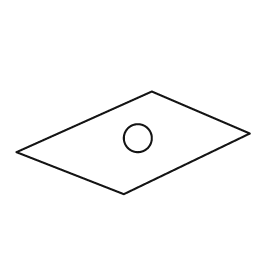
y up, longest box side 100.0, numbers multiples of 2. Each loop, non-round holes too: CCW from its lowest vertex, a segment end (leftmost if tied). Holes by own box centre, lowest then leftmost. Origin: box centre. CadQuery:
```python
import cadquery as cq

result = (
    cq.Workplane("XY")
    .moveTo(-4.0, -22.0)
    .lineTo(50.0, 4.0)
    .lineTo(8.0, 22.0)
    .lineTo(-50.0, -4.0)
    .close()
    .moveTo(2.0, 2.0)
    .circle(6.0)
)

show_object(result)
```